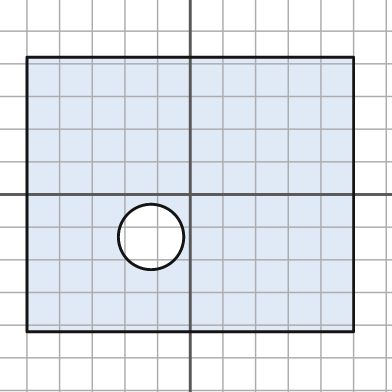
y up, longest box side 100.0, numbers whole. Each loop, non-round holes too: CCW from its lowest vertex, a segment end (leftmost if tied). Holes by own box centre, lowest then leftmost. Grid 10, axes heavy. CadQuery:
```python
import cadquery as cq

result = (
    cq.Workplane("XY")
    .moveTo(-50.0, -42.0)
    .lineTo(50.0, -42.0)
    .lineTo(50.0, 42.0)
    .lineTo(-50.0, 42.0)
    .close()
    .moveTo(-12.0, -13.0)
    .circle(10.0)
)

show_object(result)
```